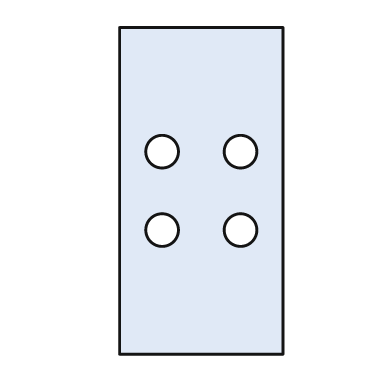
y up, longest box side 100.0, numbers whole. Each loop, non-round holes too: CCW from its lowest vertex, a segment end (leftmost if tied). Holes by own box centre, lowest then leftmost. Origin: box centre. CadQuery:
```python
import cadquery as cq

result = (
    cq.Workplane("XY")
    .moveTo(-25.0, -50.0)
    .lineTo(25.0, -50.0)
    .lineTo(25.0, 50.0)
    .lineTo(-25.0, 50.0)
    .close()
    .moveTo(-12.0, -12.0)
    .circle(5.0)
    .moveTo(12.0, -12.0)
    .circle(5.0)
    .moveTo(-12.0, 12.0)
    .circle(5.0)
    .moveTo(12.0, 12.0)
    .circle(5.0)
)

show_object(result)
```